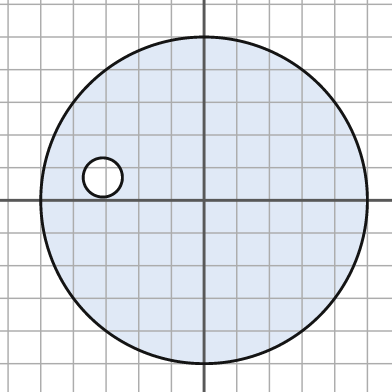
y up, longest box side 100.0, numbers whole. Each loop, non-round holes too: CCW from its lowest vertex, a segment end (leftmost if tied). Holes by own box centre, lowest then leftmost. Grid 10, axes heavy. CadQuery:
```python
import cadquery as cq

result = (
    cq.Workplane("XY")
    .moveTo(0.0, 0.0)
    .circle(50.0)
    .moveTo(-31.0, 7.0)
    .circle(6.0)
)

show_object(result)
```